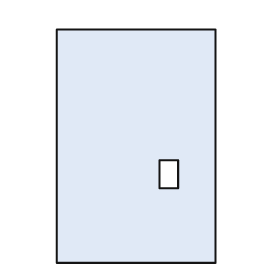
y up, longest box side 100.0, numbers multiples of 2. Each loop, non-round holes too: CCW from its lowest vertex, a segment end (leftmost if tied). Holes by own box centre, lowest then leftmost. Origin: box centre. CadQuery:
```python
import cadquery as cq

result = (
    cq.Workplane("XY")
    .moveTo(-34.0, -50.0)
    .lineTo(34.0, -50.0)
    .lineTo(34.0, 50.0)
    .lineTo(-34.0, 50.0)
    .close()
    .moveTo(10.0, -18.0)
    .lineTo(18.0, -18.0)
    .lineTo(18.0, -6.0)
    .lineTo(10.0, -6.0)
    .close()
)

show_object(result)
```